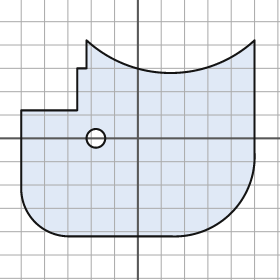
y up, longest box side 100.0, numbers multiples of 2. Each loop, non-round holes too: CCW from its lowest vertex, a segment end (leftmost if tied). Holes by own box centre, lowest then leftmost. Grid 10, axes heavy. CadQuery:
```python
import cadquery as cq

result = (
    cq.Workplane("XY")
    .moveTo(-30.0, -42.0)
    .lineTo(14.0, -42.0)
    .threePointArc((40.0, -32.0), (50.0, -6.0))
    .lineTo(50.0, 42.0)
    .threePointArc((14.0, 28.0), (-22.0, 42.0))
    .lineTo(-22.0, 30.0)
    .lineTo(-26.0, 30.0)
    .lineTo(-26.0, 12.0)
    .lineTo(-50.0, 12.0)
    .lineTo(-50.0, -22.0)
    .threePointArc((-44.0, -36.0), (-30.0, -42.0))
    .close()
    .moveTo(-18.0, 0.0)
    .circle(4.0)
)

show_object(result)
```